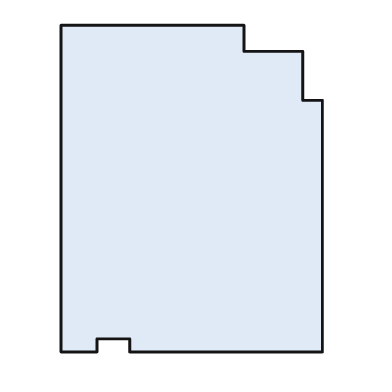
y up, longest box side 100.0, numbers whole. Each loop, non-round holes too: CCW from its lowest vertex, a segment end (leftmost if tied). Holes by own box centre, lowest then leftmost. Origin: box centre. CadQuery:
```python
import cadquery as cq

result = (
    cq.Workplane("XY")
    .moveTo(-40.0, -50.0)
    .lineTo(-29.0, -50.0)
    .lineTo(-29.0, -46.0)
    .lineTo(-19.0, -46.0)
    .lineTo(-19.0, -50.0)
    .lineTo(40.0, -50.0)
    .lineTo(40.0, 27.0)
    .lineTo(34.0, 27.0)
    .lineTo(34.0, 42.0)
    .lineTo(16.0, 42.0)
    .lineTo(16.0, 50.0)
    .lineTo(-40.0, 50.0)
    .close()
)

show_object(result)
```